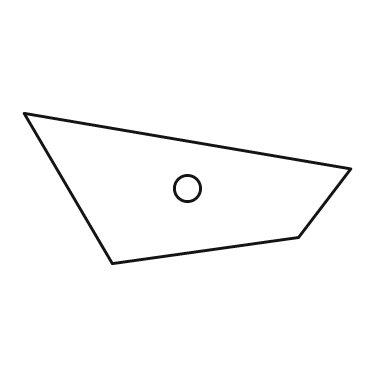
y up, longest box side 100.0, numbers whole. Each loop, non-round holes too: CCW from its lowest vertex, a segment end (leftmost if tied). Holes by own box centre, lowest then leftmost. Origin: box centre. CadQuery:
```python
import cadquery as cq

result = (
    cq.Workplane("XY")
    .moveTo(-23.0, -23.0)
    .lineTo(34.0, -15.0)
    .lineTo(50.0, 6.0)
    .lineTo(-50.0, 23.0)
    .close()
    .moveTo(0.0, 0.0)
    .circle(4.0)
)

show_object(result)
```